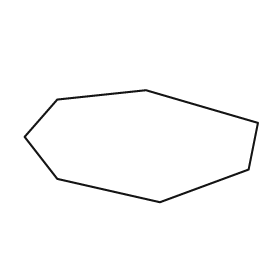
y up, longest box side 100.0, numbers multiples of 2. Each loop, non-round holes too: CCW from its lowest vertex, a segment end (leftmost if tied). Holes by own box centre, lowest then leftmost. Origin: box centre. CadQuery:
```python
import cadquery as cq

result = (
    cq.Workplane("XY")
    .moveTo(8.0, -24.0)
    .lineTo(46.0, -10.0)
    .lineTo(50.0, 10.0)
    .lineTo(2.0, 24.0)
    .lineTo(-36.0, 20.0)
    .lineTo(-50.0, 4.0)
    .lineTo(-36.0, -14.0)
    .close()
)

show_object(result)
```